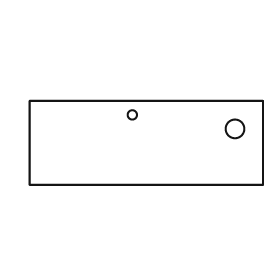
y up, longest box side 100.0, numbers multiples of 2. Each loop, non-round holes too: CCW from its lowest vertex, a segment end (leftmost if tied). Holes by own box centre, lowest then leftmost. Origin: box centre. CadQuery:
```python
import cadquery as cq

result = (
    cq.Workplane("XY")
    .moveTo(-50.0, -18.0)
    .lineTo(50.0, -18.0)
    .lineTo(50.0, 18.0)
    .lineTo(-50.0, 18.0)
    .close()
    .moveTo(38.0, 6.0)
    .circle(4.0)
    .moveTo(-6.0, 12.0)
    .circle(2.0)
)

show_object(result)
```